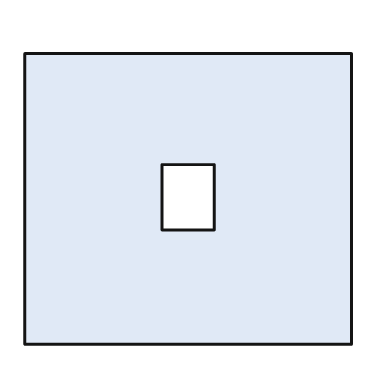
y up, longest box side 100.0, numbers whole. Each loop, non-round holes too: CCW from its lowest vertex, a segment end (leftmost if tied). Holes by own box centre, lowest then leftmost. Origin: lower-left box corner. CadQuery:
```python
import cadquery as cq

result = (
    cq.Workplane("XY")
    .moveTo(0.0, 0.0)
    .lineTo(100.0, 0.0)
    .lineTo(100.0, 89.0)
    .lineTo(0.0, 89.0)
    .close()
    .moveTo(42.0, 35.0)
    .lineTo(58.0, 35.0)
    .lineTo(58.0, 55.0)
    .lineTo(42.0, 55.0)
    .close()
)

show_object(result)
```